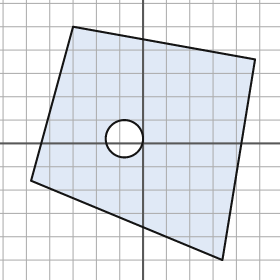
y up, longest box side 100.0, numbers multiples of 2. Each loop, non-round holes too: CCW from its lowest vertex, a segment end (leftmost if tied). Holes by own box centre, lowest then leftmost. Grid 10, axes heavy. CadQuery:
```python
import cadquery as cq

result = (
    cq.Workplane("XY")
    .moveTo(34.0, -50.0)
    .lineTo(48.0, 36.0)
    .lineTo(-30.0, 50.0)
    .lineTo(-48.0, -16.0)
    .close()
    .moveTo(-8.0, 2.0)
    .circle(8.0)
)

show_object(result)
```